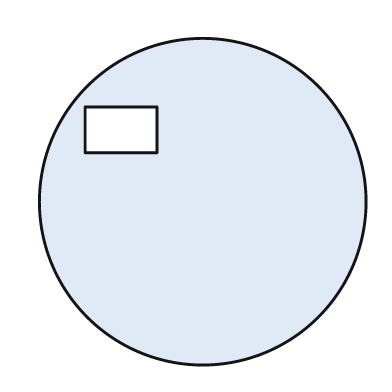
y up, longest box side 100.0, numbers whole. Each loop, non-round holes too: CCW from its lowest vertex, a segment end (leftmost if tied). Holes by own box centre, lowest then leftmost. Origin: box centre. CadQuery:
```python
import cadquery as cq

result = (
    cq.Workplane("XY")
    .moveTo(0.0, 0.0)
    .circle(50.0)
    .moveTo(-36.0, 15.0)
    .lineTo(-14.0, 15.0)
    .lineTo(-14.0, 29.0)
    .lineTo(-36.0, 29.0)
    .close()
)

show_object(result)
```